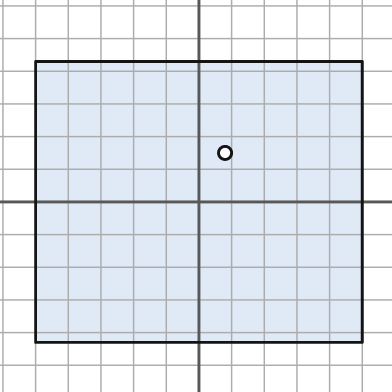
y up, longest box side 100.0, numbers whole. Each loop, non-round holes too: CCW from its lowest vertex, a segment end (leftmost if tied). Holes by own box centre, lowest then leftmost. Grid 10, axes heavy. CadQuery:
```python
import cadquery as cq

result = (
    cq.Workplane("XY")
    .moveTo(-50.0, -43.0)
    .lineTo(50.0, -43.0)
    .lineTo(50.0, 43.0)
    .lineTo(-50.0, 43.0)
    .close()
    .moveTo(8.0, 15.0)
    .circle(2.0)
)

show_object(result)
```